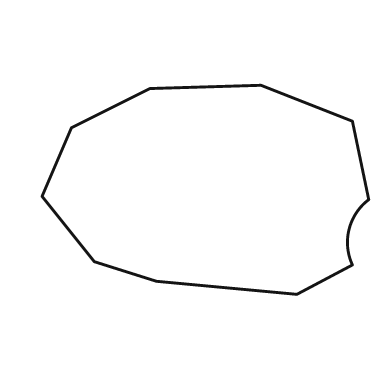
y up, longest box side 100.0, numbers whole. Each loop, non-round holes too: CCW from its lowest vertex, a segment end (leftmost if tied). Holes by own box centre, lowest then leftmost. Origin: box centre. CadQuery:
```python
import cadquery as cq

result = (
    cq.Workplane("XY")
    .moveTo(28.0, -32.0)
    .lineTo(45.0, -23.0)
    .threePointArc((44.0, -12.0), (50.0, -3.0))
    .lineTo(45.0, 21.0)
    .lineTo(17.0, 32.0)
    .lineTo(-17.0, 31.0)
    .lineTo(-41.0, 19.0)
    .lineTo(-50.0, -2.0)
    .lineTo(-34.0, -22.0)
    .lineTo(-15.0, -28.0)
    .close()
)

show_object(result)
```